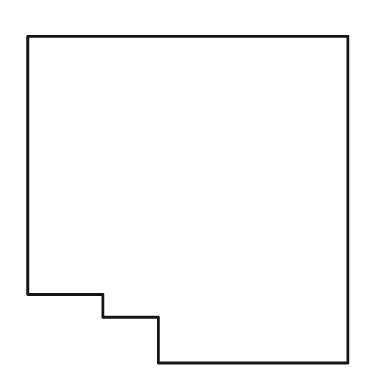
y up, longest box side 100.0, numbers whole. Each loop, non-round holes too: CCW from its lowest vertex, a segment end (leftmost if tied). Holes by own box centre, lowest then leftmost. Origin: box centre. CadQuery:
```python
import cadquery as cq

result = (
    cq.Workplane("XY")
    .moveTo(-9.0, -50.0)
    .lineTo(49.0, -50.0)
    .lineTo(49.0, 50.0)
    .lineTo(-49.0, 50.0)
    .lineTo(-49.0, -29.0)
    .lineTo(-26.0, -29.0)
    .lineTo(-26.0, -36.0)
    .lineTo(-9.0, -36.0)
    .close()
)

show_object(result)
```